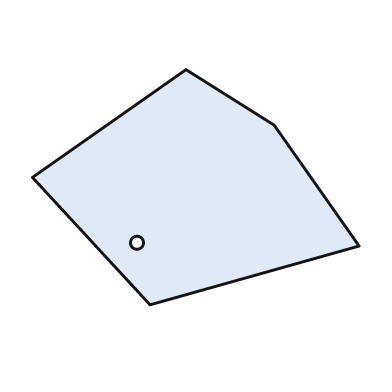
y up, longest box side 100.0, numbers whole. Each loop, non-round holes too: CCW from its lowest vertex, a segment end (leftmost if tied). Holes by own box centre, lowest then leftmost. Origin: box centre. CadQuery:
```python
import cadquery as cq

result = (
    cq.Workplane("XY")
    .moveTo(-14.0, -36.0)
    .lineTo(50.0, -18.0)
    .lineTo(24.0, 19.0)
    .lineTo(-3.0, 36.0)
    .lineTo(-50.0, 3.0)
    .close()
    .moveTo(-18.0, -17.0)
    .circle(2.0)
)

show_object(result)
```